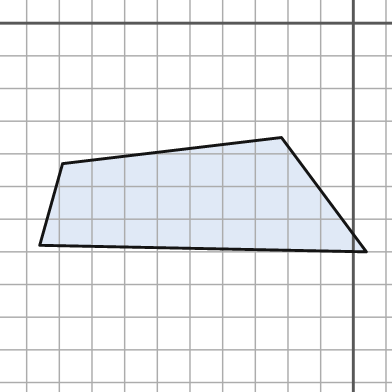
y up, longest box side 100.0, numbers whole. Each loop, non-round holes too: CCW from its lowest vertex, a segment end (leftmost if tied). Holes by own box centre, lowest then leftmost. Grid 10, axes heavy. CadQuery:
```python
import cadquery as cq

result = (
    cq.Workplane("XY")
    .moveTo(4.0, -70.0)
    .lineTo(-22.0, -35.0)
    .lineTo(-89.0, -43.0)
    .lineTo(-96.0, -68.0)
    .close()
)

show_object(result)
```